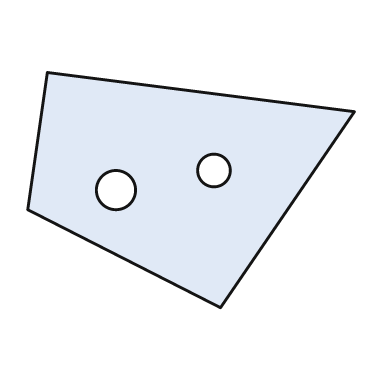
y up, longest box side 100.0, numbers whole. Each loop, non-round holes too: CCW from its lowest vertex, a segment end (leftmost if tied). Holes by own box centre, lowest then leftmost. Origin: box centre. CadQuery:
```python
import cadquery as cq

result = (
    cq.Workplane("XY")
    .moveTo(9.0, -36.0)
    .lineTo(50.0, 24.0)
    .lineTo(-44.0, 36.0)
    .lineTo(-50.0, -6.0)
    .close()
    .moveTo(-23.0, 0.0)
    .circle(6.0)
    .moveTo(7.0, 6.0)
    .circle(5.0)
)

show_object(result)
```